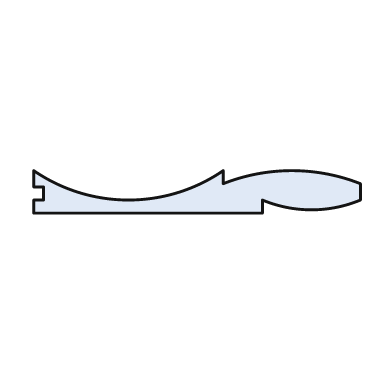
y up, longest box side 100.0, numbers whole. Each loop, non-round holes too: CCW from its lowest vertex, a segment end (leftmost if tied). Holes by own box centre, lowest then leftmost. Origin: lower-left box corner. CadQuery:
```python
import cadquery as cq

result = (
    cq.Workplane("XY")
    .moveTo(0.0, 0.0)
    .lineTo(70.0, 0.0)
    .lineTo(70.0, 4.0)
    .threePointArc((85.0, 1.0), (100.0, 4.0))
    .lineTo(100.0, 9.0)
    .threePointArc((79.0, 13.0), (58.0, 9.0))
    .lineTo(58.0, 13.0)
    .threePointArc((29.0, 4.0), (0.0, 13.0))
    .lineTo(0.0, 8.0)
    .lineTo(3.0, 8.0)
    .lineTo(3.0, 4.0)
    .lineTo(0.0, 4.0)
    .close()
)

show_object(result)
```